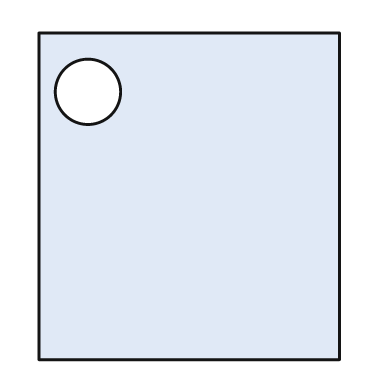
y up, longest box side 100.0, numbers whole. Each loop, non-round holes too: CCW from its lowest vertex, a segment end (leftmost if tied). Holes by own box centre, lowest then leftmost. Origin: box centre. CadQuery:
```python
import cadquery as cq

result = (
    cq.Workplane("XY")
    .moveTo(-46.0, -50.0)
    .lineTo(46.0, -50.0)
    .lineTo(46.0, 50.0)
    .lineTo(-46.0, 50.0)
    .close()
    .moveTo(-31.0, 32.0)
    .circle(10.0)
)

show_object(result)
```